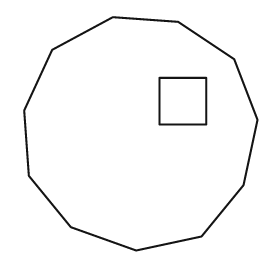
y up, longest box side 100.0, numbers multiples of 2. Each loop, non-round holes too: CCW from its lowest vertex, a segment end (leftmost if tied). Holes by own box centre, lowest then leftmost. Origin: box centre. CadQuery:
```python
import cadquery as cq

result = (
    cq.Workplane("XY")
    .moveTo(-2.0, -50.0)
    .lineTo(26.0, -44.0)
    .lineTo(44.0, -22.0)
    .lineTo(50.0, 6.0)
    .lineTo(40.0, 32.0)
    .lineTo(16.0, 48.0)
    .lineTo(-12.0, 50.0)
    .lineTo(-38.0, 36.0)
    .lineTo(-50.0, 10.0)
    .lineTo(-48.0, -18.0)
    .lineTo(-30.0, -40.0)
    .close()
    .moveTo(8.0, 4.0)
    .lineTo(28.0, 4.0)
    .lineTo(28.0, 24.0)
    .lineTo(8.0, 24.0)
    .close()
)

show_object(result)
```